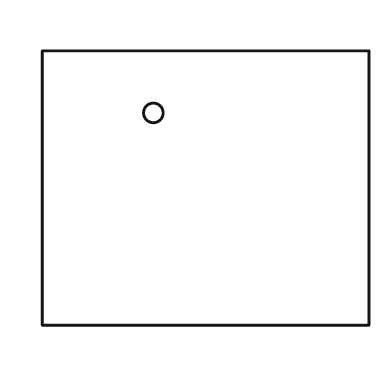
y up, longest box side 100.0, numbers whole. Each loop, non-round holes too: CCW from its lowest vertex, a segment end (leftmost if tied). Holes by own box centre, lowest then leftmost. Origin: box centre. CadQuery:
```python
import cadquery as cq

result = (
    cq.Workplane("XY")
    .moveTo(-50.0, -42.0)
    .lineTo(50.0, -42.0)
    .lineTo(50.0, 42.0)
    .lineTo(-50.0, 42.0)
    .close()
    .moveTo(-16.0, 23.0)
    .circle(3.0)
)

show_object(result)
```